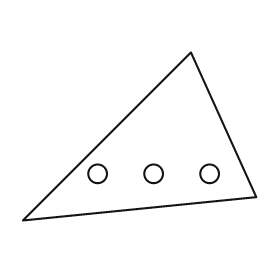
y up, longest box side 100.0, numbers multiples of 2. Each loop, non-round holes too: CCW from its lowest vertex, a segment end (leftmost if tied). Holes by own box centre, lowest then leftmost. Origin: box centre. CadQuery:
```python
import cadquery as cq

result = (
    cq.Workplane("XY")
    .moveTo(-50.0, -36.0)
    .lineTo(50.0, -26.0)
    .lineTo(22.0, 36.0)
    .close()
    .moveTo(-18.0, -16.0)
    .circle(4.0)
    .moveTo(6.0, -16.0)
    .circle(4.0)
    .moveTo(30.0, -16.0)
    .circle(4.0)
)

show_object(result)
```